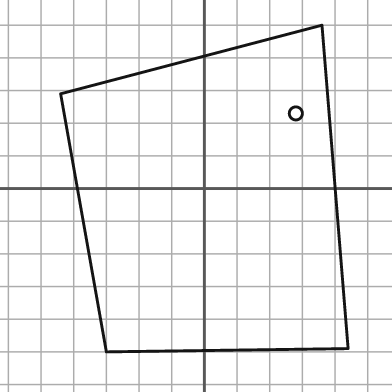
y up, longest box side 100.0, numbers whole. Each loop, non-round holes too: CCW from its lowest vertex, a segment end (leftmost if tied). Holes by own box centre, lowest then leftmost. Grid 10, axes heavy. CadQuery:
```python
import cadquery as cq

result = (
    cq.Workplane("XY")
    .moveTo(-30.0, -50.0)
    .lineTo(44.0, -49.0)
    .lineTo(36.0, 50.0)
    .lineTo(-44.0, 29.0)
    .close()
    .moveTo(28.0, 23.0)
    .circle(2.0)
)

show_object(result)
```